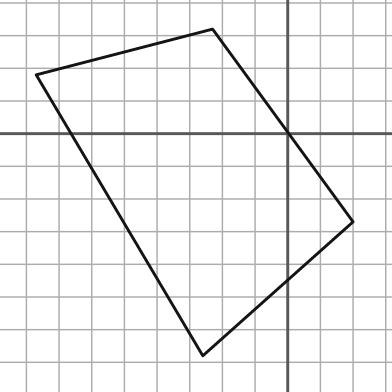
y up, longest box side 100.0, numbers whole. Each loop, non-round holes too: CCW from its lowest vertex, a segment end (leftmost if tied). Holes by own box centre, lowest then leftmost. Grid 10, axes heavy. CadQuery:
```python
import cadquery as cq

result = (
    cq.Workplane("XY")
    .moveTo(-26.0, -68.0)
    .lineTo(20.0, -27.0)
    .lineTo(-23.0, 32.0)
    .lineTo(-77.0, 18.0)
    .close()
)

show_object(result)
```